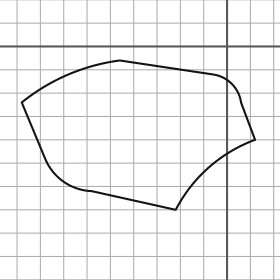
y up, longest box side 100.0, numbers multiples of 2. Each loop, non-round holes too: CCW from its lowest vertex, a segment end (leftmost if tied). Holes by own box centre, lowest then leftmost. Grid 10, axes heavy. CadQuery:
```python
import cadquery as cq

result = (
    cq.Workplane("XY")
    .moveTo(-22.0, -70.0)
    .threePointArc((-8.0, -52.0), (12.0, -40.0))
    .lineTo(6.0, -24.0)
    .threePointArc((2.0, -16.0), (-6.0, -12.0))
    .lineTo(-46.0, -6.0)
    .threePointArc((-68.0, -12.0), (-88.0, -24.0))
    .lineTo(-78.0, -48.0)
    .threePointArc((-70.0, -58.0), (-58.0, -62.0))
    .close()
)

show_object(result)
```